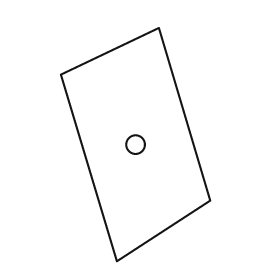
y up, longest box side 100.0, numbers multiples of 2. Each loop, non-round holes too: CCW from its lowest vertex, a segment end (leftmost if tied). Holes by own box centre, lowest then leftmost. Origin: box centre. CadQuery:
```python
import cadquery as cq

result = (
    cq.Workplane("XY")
    .moveTo(-8.0, -50.0)
    .lineTo(32.0, -24.0)
    .lineTo(10.0, 50.0)
    .lineTo(-32.0, 30.0)
    .close()
    .moveTo(0.0, 0.0)
    .circle(4.0)
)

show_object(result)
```